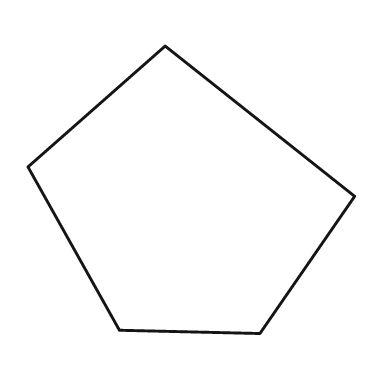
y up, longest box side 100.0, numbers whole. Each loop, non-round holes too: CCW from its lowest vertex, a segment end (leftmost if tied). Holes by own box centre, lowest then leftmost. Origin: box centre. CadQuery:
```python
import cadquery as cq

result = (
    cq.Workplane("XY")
    .moveTo(21.0, -44.0)
    .lineTo(50.0, -2.0)
    .lineTo(-8.0, 44.0)
    .lineTo(-50.0, 7.0)
    .lineTo(-22.0, -43.0)
    .close()
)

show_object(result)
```